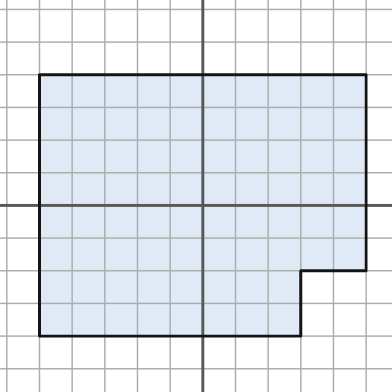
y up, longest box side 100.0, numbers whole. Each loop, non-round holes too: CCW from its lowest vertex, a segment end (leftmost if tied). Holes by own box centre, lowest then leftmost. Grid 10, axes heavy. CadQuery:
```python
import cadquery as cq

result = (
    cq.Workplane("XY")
    .moveTo(-50.0, -40.0)
    .lineTo(30.0, -40.0)
    .lineTo(30.0, -20.0)
    .lineTo(50.0, -20.0)
    .lineTo(50.0, 40.0)
    .lineTo(-50.0, 40.0)
    .close()
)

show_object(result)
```